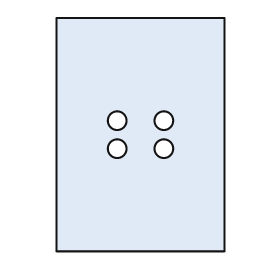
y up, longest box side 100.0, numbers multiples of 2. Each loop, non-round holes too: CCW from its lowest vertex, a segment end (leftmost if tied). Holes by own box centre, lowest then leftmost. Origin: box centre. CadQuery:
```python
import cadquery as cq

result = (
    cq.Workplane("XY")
    .moveTo(-36.0, -50.0)
    .lineTo(36.0, -50.0)
    .lineTo(36.0, 50.0)
    .lineTo(-36.0, 50.0)
    .close()
    .moveTo(-10.0, -6.0)
    .circle(4.0)
    .moveTo(10.0, -6.0)
    .circle(4.0)
    .moveTo(-10.0, 6.0)
    .circle(4.0)
    .moveTo(10.0, 6.0)
    .circle(4.0)
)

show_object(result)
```